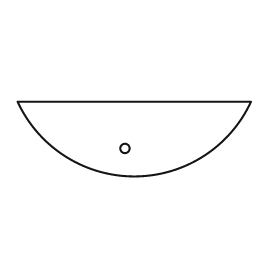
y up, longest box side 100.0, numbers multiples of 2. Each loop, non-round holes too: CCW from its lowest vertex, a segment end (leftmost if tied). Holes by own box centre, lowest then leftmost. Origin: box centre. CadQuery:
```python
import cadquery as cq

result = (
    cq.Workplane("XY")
    .moveTo(-50.0, 16.0)
    .threePointArc((0.0, -16.0), (50.0, 16.0))
    .close()
    .moveTo(-4.0, -4.0)
    .circle(2.0)
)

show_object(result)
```